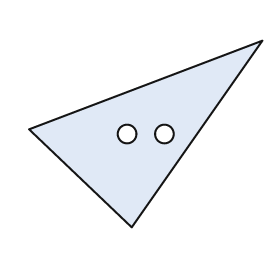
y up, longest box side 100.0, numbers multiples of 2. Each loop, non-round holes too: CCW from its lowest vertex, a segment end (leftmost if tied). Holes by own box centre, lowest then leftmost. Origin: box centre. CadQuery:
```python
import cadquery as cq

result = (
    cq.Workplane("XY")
    .moveTo(-6.0, -40.0)
    .lineTo(50.0, 40.0)
    .lineTo(-50.0, 2.0)
    .close()
    .moveTo(-8.0, 0.0)
    .circle(4.0)
    .moveTo(8.0, 0.0)
    .circle(4.0)
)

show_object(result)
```